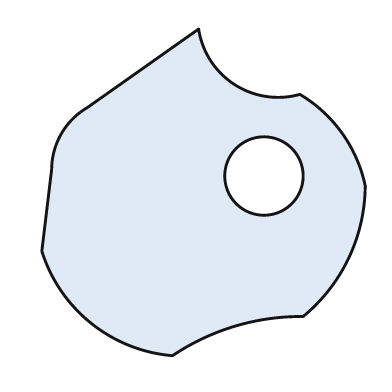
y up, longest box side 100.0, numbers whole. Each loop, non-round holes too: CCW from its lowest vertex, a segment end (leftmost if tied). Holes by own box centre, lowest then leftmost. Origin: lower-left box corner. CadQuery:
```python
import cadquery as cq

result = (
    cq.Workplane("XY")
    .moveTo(40.0, 0.0)
    .threePointArc((59.0, 9.0), (80.0, 12.0))
    .threePointArc((94.0, 30.0), (99.0, 52.0))
    .threePointArc((92.0, 68.0), (79.0, 80.0))
    .threePointArc((59.0, 83.0), (48.0, 100.0))
    .lineTo(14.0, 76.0)
    .threePointArc((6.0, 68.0), (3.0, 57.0))
    .lineTo(0.0, 32.0)
    .threePointArc((15.0, 10.0), (40.0, 0.0))
    .close()
    .moveTo(68.0, 55.0)
    .circle(12.0)
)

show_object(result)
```